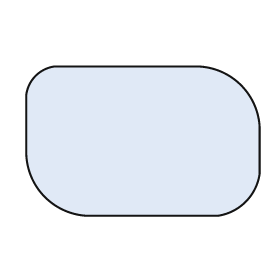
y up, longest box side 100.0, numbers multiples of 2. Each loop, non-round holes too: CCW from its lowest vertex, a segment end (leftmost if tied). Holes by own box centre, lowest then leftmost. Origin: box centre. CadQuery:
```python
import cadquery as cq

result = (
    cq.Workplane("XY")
    .moveTo(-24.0, -32.0)
    .lineTo(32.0, -32.0)
    .threePointArc((44.0, -26.0), (50.0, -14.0))
    .lineTo(50.0, 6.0)
    .threePointArc((42.0, 24.0), (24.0, 32.0))
    .lineTo(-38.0, 32.0)
    .threePointArc((-46.0, 28.0), (-50.0, 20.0))
    .lineTo(-50.0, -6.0)
    .threePointArc((-42.0, -24.0), (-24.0, -32.0))
    .close()
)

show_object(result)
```